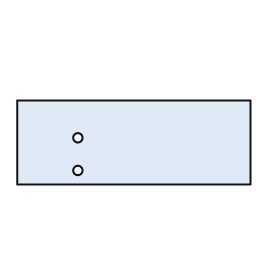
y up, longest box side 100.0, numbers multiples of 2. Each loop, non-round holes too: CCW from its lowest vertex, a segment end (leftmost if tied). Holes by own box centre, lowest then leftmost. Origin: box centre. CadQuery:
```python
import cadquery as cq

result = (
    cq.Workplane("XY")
    .moveTo(-50.0, -18.0)
    .lineTo(50.0, -18.0)
    .lineTo(50.0, 18.0)
    .lineTo(-50.0, 18.0)
    .close()
    .moveTo(-24.0, -12.0)
    .circle(2.0)
    .moveTo(-24.0, 2.0)
    .circle(2.0)
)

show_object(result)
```